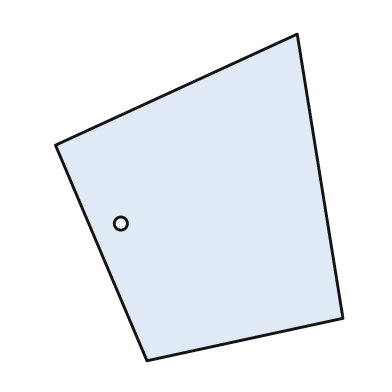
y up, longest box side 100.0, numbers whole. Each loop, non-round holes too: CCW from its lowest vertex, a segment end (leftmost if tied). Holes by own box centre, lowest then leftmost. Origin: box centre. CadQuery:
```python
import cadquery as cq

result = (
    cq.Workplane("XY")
    .moveTo(-16.0, -50.0)
    .lineTo(44.0, -37.0)
    .lineTo(30.0, 50.0)
    .lineTo(-44.0, 16.0)
    .close()
    .moveTo(-24.0, -8.0)
    .circle(2.0)
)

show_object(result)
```